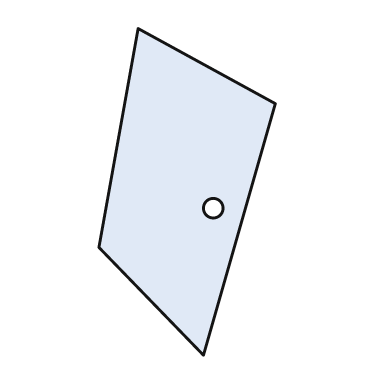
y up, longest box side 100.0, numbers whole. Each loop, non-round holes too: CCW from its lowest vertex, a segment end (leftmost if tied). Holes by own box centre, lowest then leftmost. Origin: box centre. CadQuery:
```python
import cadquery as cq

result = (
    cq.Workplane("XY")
    .moveTo(5.0, -50.0)
    .lineTo(27.0, 27.0)
    .lineTo(-15.0, 50.0)
    .lineTo(-27.0, -17.0)
    .close()
    .moveTo(8.0, -5.0)
    .circle(3.0)
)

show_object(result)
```